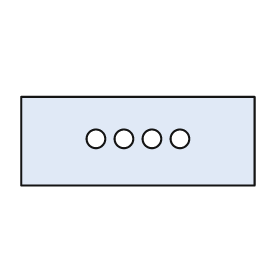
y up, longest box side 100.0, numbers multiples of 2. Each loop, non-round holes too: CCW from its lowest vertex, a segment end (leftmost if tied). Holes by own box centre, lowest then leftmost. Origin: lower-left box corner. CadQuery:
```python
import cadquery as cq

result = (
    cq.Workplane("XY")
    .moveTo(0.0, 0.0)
    .lineTo(100.0, 0.0)
    .lineTo(100.0, 38.0)
    .lineTo(0.0, 38.0)
    .close()
    .moveTo(32.0, 20.0)
    .circle(4.0)
    .moveTo(44.0, 20.0)
    .circle(4.0)
    .moveTo(56.0, 20.0)
    .circle(4.0)
    .moveTo(68.0, 20.0)
    .circle(4.0)
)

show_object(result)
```